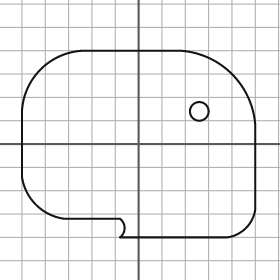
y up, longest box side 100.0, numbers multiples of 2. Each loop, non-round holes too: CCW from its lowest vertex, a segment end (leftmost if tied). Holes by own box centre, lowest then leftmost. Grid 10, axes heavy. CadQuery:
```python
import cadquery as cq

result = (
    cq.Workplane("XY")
    .moveTo(-8.0, -40.0)
    .lineTo(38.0, -40.0)
    .threePointArc((46.0, -36.0), (50.0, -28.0))
    .lineTo(50.0, 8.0)
    .threePointArc((40.0, 30.0), (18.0, 40.0))
    .lineTo(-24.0, 40.0)
    .threePointArc((-42.0, 32.0), (-50.0, 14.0))
    .lineTo(-50.0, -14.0)
    .threePointArc((-44.0, -26.0), (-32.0, -32.0))
    .lineTo(-8.0, -32.0)
    .threePointArc((-6.0, -36.0), (-8.0, -40.0))
    .close()
    .moveTo(26.0, 14.0)
    .circle(4.0)
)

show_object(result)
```